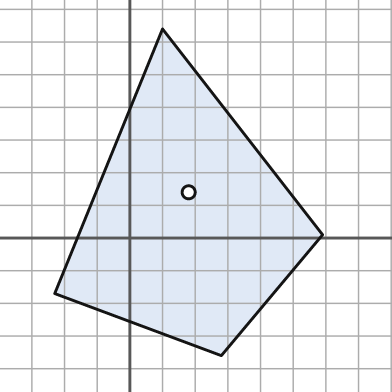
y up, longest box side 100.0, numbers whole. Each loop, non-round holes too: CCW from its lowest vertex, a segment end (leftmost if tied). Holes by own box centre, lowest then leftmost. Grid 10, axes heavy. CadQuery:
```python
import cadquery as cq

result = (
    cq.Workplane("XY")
    .moveTo(28.0, -36.0)
    .lineTo(59.0, 1.0)
    .lineTo(10.0, 64.0)
    .lineTo(-23.0, -17.0)
    .close()
    .moveTo(18.0, 14.0)
    .circle(2.0)
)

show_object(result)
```